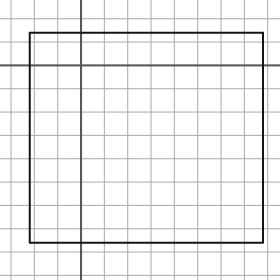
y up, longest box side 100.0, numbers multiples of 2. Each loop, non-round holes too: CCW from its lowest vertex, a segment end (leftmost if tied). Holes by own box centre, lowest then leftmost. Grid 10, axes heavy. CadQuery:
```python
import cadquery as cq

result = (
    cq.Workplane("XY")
    .moveTo(-22.0, -76.0)
    .lineTo(78.0, -76.0)
    .lineTo(78.0, 14.0)
    .lineTo(-22.0, 14.0)
    .close()
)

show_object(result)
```